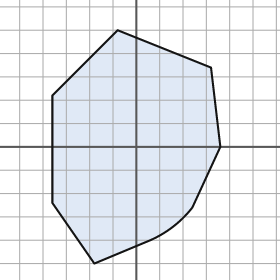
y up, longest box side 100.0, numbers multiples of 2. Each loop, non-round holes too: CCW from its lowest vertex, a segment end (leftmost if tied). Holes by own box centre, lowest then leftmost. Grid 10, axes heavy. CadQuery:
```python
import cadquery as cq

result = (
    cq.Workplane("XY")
    .moveTo(-18.0, -50.0)
    .lineTo(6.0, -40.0)
    .threePointArc((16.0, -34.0), (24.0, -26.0))
    .lineTo(36.0, 0.0)
    .lineTo(32.0, 34.0)
    .lineTo(-8.0, 50.0)
    .lineTo(-36.0, 22.0)
    .lineTo(-36.0, -24.0)
    .close()
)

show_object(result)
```